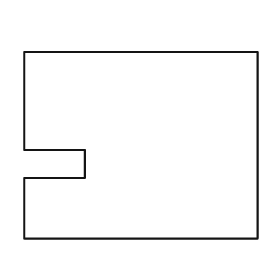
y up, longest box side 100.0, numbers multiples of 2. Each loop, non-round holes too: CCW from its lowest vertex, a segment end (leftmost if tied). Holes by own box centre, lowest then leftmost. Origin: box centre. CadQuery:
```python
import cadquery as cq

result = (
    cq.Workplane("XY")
    .moveTo(-50.0, -40.0)
    .lineTo(50.0, -40.0)
    .lineTo(50.0, 40.0)
    .lineTo(-50.0, 40.0)
    .lineTo(-50.0, -2.0)
    .lineTo(-24.0, -2.0)
    .lineTo(-24.0, -14.0)
    .lineTo(-50.0, -14.0)
    .close()
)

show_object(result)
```